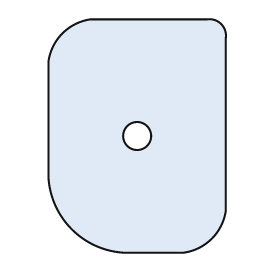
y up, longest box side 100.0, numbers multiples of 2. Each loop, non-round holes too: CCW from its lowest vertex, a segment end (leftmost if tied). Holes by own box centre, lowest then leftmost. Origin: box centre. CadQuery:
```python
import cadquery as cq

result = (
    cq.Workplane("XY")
    .moveTo(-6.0, -50.0)
    .lineTo(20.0, -50.0)
    .threePointArc((32.0, -44.0), (38.0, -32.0))
    .lineTo(38.0, 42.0)
    .threePointArc((36.0, 48.0), (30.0, 50.0))
    .lineTo(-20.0, 50.0)
    .threePointArc((-32.0, 44.0), (-38.0, 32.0))
    .lineTo(-38.0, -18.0)
    .threePointArc((-28.0, -40.0), (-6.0, -50.0))
    .close()
    .moveTo(0.0, 0.0)
    .circle(6.0)
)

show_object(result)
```